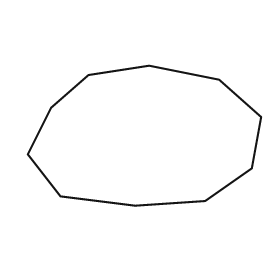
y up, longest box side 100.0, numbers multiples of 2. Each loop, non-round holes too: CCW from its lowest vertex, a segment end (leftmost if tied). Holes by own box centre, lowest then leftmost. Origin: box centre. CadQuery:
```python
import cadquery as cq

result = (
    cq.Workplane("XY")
    .moveTo(-4.0, -30.0)
    .lineTo(26.0, -28.0)
    .lineTo(46.0, -14.0)
    .lineTo(50.0, 8.0)
    .lineTo(32.0, 24.0)
    .lineTo(2.0, 30.0)
    .lineTo(-24.0, 26.0)
    .lineTo(-40.0, 12.0)
    .lineTo(-50.0, -8.0)
    .lineTo(-36.0, -26.0)
    .close()
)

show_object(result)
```